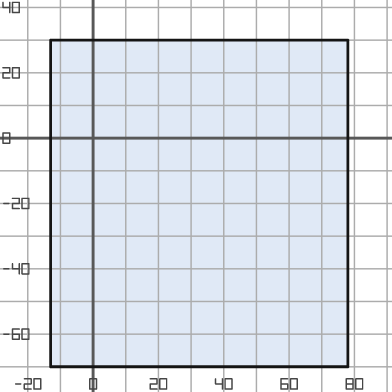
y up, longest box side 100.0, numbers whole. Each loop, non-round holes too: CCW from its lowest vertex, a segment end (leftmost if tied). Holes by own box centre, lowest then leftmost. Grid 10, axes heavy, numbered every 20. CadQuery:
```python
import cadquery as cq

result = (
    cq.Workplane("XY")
    .moveTo(-13.0, -70.0)
    .lineTo(78.0, -70.0)
    .lineTo(78.0, 30.0)
    .lineTo(-13.0, 30.0)
    .close()
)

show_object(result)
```